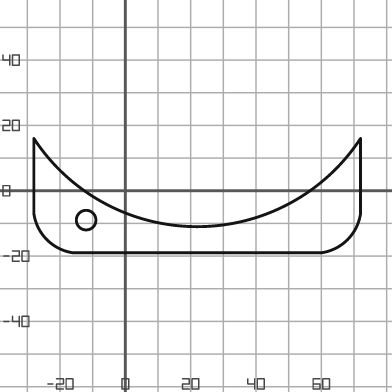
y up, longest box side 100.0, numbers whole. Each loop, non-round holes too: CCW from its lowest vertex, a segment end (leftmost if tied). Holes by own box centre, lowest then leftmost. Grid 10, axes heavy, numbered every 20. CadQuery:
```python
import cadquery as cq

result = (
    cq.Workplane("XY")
    .moveTo(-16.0, -19.0)
    .lineTo(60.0, -19.0)
    .threePointArc((68.0, -15.0), (72.0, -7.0))
    .lineTo(72.0, 16.0)
    .threePointArc((22.0, -11.0), (-28.0, 16.0))
    .lineTo(-28.0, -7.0)
    .threePointArc((-24.0, -15.0), (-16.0, -19.0))
    .close()
    .moveTo(-12.0, -9.0)
    .circle(3.0)
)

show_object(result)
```